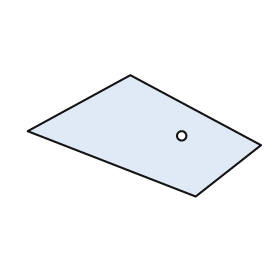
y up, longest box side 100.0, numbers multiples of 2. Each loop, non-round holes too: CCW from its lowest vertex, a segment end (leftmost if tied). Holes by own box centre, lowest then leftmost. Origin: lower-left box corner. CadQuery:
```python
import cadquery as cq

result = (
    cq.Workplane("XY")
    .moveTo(72.0, 0.0)
    .lineTo(100.0, 22.0)
    .lineTo(44.0, 52.0)
    .lineTo(0.0, 28.0)
    .close()
    .moveTo(66.0, 26.0)
    .circle(2.0)
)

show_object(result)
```